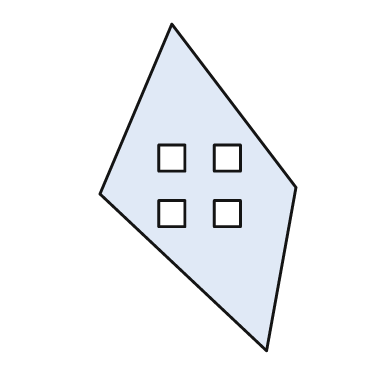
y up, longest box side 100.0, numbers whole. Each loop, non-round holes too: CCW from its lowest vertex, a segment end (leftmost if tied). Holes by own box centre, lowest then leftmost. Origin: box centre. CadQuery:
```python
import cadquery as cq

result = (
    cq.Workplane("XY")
    .moveTo(21.0, -50.0)
    .lineTo(30.0, 0.0)
    .lineTo(-8.0, 50.0)
    .lineTo(-30.0, -2.0)
    .close()
    .moveTo(-12.0, -12.0)
    .lineTo(-4.0, -12.0)
    .lineTo(-4.0, -4.0)
    .lineTo(-12.0, -4.0)
    .close()
    .moveTo(5.0, -12.0)
    .lineTo(13.0, -12.0)
    .lineTo(13.0, -4.0)
    .lineTo(5.0, -4.0)
    .close()
    .moveTo(-12.0, 5.0)
    .lineTo(-4.0, 5.0)
    .lineTo(-4.0, 13.0)
    .lineTo(-12.0, 13.0)
    .close()
    .moveTo(5.0, 5.0)
    .lineTo(13.0, 5.0)
    .lineTo(13.0, 13.0)
    .lineTo(5.0, 13.0)
    .close()
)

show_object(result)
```